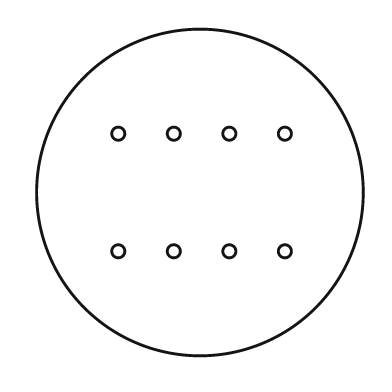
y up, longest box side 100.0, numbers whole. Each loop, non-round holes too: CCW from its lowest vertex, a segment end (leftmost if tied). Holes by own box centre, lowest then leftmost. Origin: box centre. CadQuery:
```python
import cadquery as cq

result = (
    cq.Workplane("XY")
    .moveTo(0.0, 0.0)
    .circle(50.0)
    .moveTo(-25.0, -18.0)
    .circle(2.0)
    .moveTo(-8.0, -18.0)
    .circle(2.0)
    .moveTo(9.0, -18.0)
    .circle(2.0)
    .moveTo(26.0, -18.0)
    .circle(2.0)
    .moveTo(-25.0, 18.0)
    .circle(2.0)
    .moveTo(-8.0, 18.0)
    .circle(2.0)
    .moveTo(9.0, 18.0)
    .circle(2.0)
    .moveTo(26.0, 18.0)
    .circle(2.0)
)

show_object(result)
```